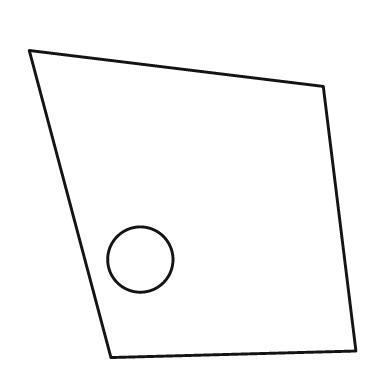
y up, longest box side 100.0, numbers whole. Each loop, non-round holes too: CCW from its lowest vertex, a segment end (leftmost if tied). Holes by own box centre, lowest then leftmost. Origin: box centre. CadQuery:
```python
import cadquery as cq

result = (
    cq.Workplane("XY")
    .moveTo(-25.0, -47.0)
    .lineTo(50.0, -45.0)
    .lineTo(40.0, 36.0)
    .lineTo(-50.0, 47.0)
    .close()
    .moveTo(-16.0, -17.0)
    .circle(10.0)
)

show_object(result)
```